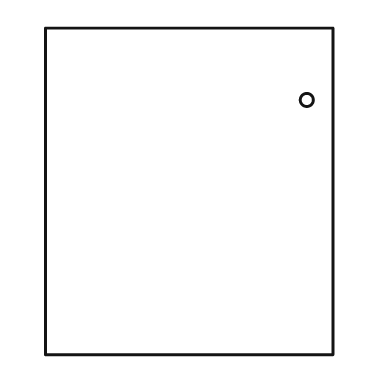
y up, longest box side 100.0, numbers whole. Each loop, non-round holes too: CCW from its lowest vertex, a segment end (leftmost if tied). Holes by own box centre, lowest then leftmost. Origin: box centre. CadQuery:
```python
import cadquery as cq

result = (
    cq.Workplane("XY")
    .moveTo(-44.0, -50.0)
    .lineTo(44.0, -50.0)
    .lineTo(44.0, 50.0)
    .lineTo(-44.0, 50.0)
    .close()
    .moveTo(36.0, 28.0)
    .circle(2.0)
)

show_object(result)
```